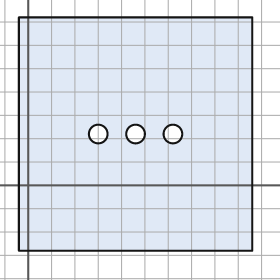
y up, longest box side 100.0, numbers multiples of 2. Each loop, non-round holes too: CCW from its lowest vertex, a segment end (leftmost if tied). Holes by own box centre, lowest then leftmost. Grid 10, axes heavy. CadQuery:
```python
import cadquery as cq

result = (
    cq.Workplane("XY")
    .moveTo(-4.0, -28.0)
    .lineTo(96.0, -28.0)
    .lineTo(96.0, 72.0)
    .lineTo(-4.0, 72.0)
    .close()
    .moveTo(30.0, 22.0)
    .circle(4.0)
    .moveTo(46.0, 22.0)
    .circle(4.0)
    .moveTo(62.0, 22.0)
    .circle(4.0)
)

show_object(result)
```